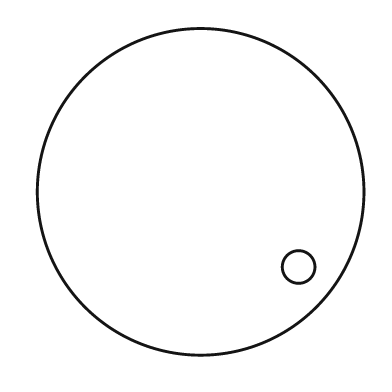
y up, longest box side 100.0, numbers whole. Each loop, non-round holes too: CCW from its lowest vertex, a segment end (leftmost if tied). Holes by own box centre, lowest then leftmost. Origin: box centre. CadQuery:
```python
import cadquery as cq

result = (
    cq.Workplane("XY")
    .moveTo(0.0, 0.0)
    .circle(50.0)
    .moveTo(30.0, -23.0)
    .circle(5.0)
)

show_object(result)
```